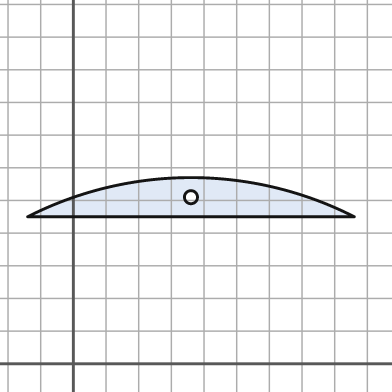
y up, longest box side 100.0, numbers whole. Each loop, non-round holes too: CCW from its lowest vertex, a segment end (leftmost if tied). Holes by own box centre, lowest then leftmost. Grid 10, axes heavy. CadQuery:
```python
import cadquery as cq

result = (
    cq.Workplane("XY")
    .moveTo(-14.0, 45.0)
    .lineTo(86.0, 45.0)
    .threePointArc((36.0, 57.0), (-14.0, 45.0))
    .close()
    .moveTo(36.0, 51.0)
    .circle(2.0)
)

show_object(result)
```